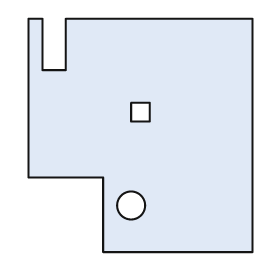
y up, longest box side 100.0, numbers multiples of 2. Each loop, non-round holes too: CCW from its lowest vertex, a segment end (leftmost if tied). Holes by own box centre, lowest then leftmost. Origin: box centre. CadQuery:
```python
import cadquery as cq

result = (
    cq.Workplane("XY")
    .moveTo(-16.0, -50.0)
    .lineTo(48.0, -50.0)
    .lineTo(48.0, 50.0)
    .lineTo(-32.0, 50.0)
    .lineTo(-32.0, 28.0)
    .lineTo(-42.0, 28.0)
    .lineTo(-42.0, 50.0)
    .lineTo(-48.0, 50.0)
    .lineTo(-48.0, -18.0)
    .lineTo(-16.0, -18.0)
    .close()
    .moveTo(-4.0, -30.0)
    .circle(6.0)
    .moveTo(-4.0, 6.0)
    .lineTo(4.0, 6.0)
    .lineTo(4.0, 14.0)
    .lineTo(-4.0, 14.0)
    .close()
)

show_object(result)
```